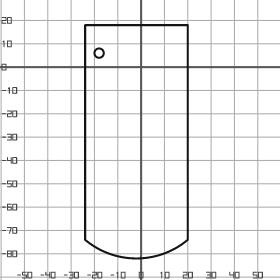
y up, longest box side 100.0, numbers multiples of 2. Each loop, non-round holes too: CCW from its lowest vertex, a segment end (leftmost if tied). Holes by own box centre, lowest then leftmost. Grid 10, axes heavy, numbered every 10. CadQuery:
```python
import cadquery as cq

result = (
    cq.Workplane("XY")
    .moveTo(-24.0, -74.0)
    .threePointArc((-2.0, -82.0), (20.0, -74.0))
    .lineTo(20.0, 18.0)
    .lineTo(-24.0, 18.0)
    .close()
    .moveTo(-18.0, 6.0)
    .circle(2.0)
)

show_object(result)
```